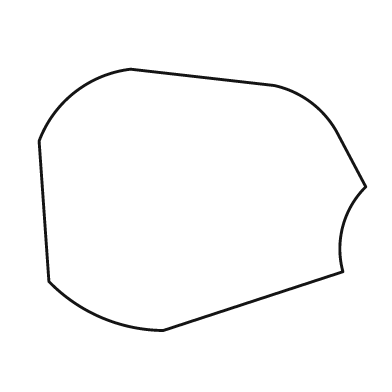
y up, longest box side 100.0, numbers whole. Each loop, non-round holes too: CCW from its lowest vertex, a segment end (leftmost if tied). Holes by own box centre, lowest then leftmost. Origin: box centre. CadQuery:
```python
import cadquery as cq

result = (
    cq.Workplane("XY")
    .moveTo(-12.0, -40.0)
    .lineTo(43.0, -22.0)
    .threePointArc((43.0, -8.0), (50.0, 4.0))
    .lineTo(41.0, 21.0)
    .threePointArc((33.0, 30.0), (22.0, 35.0))
    .lineTo(-22.0, 40.0)
    .threePointArc((-39.0, 33.0), (-50.0, 18.0))
    .lineTo(-47.0, -25.0)
    .threePointArc((-31.0, -36.0), (-12.0, -40.0))
    .close()
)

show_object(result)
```